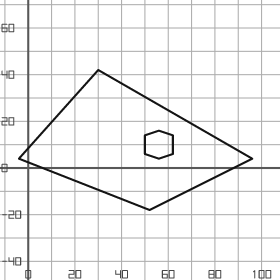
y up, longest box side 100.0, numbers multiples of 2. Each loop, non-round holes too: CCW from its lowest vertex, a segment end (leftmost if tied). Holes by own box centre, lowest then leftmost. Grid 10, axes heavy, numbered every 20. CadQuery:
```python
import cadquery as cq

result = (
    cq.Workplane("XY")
    .moveTo(52.0, -18.0)
    .lineTo(96.0, 4.0)
    .lineTo(30.0, 42.0)
    .lineTo(-4.0, 4.0)
    .close()
    .moveTo(56.0, 4.0)
    .lineTo(62.0, 6.0)
    .lineTo(62.0, 14.0)
    .lineTo(56.0, 16.0)
    .lineTo(50.0, 14.0)
    .lineTo(50.0, 6.0)
    .close()
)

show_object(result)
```